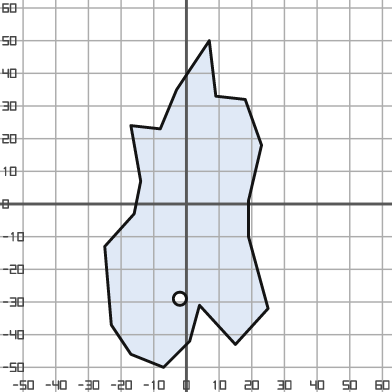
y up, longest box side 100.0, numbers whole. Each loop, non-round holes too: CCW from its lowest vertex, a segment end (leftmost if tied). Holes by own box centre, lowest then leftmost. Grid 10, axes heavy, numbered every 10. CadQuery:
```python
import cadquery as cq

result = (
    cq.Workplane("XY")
    .moveTo(-7.0, -50.0)
    .lineTo(1.0, -42.0)
    .lineTo(4.0, -31.0)
    .lineTo(15.0, -43.0)
    .lineTo(25.0, -32.0)
    .lineTo(19.0, -10.0)
    .lineTo(19.0, 1.0)
    .lineTo(23.0, 18.0)
    .lineTo(18.0, 32.0)
    .lineTo(9.0, 33.0)
    .lineTo(7.0, 50.0)
    .lineTo(-3.0, 35.0)
    .lineTo(-8.0, 23.0)
    .lineTo(-17.0, 24.0)
    .lineTo(-14.0, 7.0)
    .lineTo(-16.0, -3.0)
    .lineTo(-25.0, -13.0)
    .lineTo(-23.0, -37.0)
    .lineTo(-17.0, -46.0)
    .close()
    .moveTo(-2.0, -29.0)
    .circle(2.0)
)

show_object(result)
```